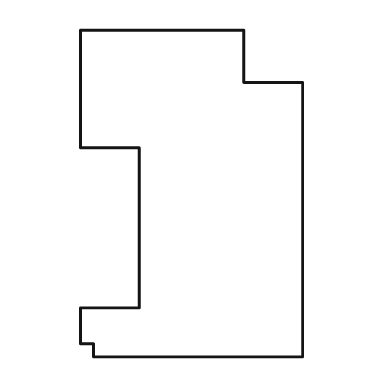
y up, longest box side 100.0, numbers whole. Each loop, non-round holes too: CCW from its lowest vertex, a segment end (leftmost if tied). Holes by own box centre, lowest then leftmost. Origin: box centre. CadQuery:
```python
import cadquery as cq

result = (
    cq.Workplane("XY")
    .moveTo(-30.0, -50.0)
    .lineTo(34.0, -50.0)
    .lineTo(34.0, 34.0)
    .lineTo(16.0, 34.0)
    .lineTo(16.0, 50.0)
    .lineTo(-34.0, 50.0)
    .lineTo(-34.0, 14.0)
    .lineTo(-16.0, 14.0)
    .lineTo(-16.0, -35.0)
    .lineTo(-34.0, -35.0)
    .lineTo(-34.0, -46.0)
    .lineTo(-30.0, -46.0)
    .close()
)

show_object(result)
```